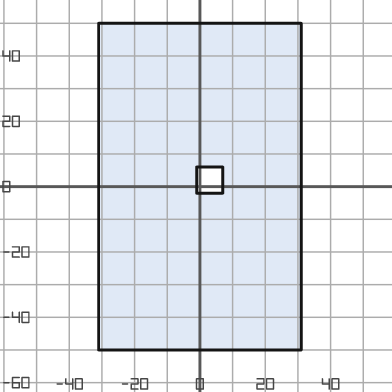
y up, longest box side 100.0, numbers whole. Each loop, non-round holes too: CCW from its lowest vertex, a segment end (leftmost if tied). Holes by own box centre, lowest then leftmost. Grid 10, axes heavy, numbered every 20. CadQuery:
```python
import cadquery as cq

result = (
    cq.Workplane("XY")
    .moveTo(-31.0, -50.0)
    .lineTo(31.0, -50.0)
    .lineTo(31.0, 50.0)
    .lineTo(-31.0, 50.0)
    .close()
    .moveTo(-1.0, -2.0)
    .lineTo(7.0, -2.0)
    .lineTo(7.0, 6.0)
    .lineTo(-1.0, 6.0)
    .close()
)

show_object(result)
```